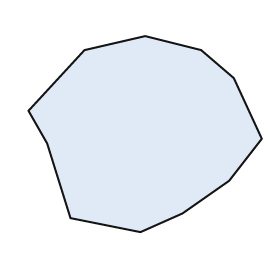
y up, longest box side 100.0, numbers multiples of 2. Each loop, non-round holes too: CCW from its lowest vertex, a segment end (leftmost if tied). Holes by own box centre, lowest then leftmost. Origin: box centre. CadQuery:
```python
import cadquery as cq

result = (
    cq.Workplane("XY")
    .moveTo(-2.0, -42.0)
    .lineTo(16.0, -34.0)
    .lineTo(36.0, -20.0)
    .lineTo(50.0, -2.0)
    .lineTo(38.0, 24.0)
    .lineTo(24.0, 36.0)
    .lineTo(0.0, 42.0)
    .lineTo(-26.0, 36.0)
    .lineTo(-50.0, 10.0)
    .lineTo(-42.0, -4.0)
    .lineTo(-32.0, -36.0)
    .close()
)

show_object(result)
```